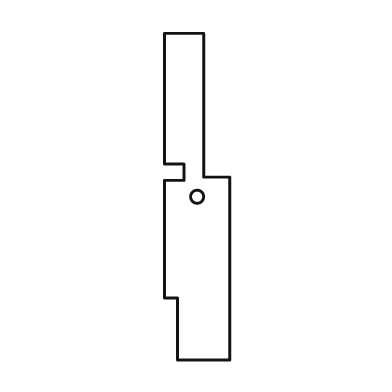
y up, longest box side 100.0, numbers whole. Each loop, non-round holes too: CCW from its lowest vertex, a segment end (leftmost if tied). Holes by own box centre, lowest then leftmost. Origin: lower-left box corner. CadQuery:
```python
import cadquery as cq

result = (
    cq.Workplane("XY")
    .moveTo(4.0, 0.0)
    .lineTo(20.0, 0.0)
    .lineTo(20.0, 56.0)
    .lineTo(12.0, 56.0)
    .lineTo(12.0, 100.0)
    .lineTo(0.0, 100.0)
    .lineTo(0.0, 60.0)
    .lineTo(6.0, 60.0)
    .lineTo(6.0, 55.0)
    .lineTo(0.0, 55.0)
    .lineTo(0.0, 19.0)
    .lineTo(4.0, 19.0)
    .close()
    .moveTo(10.0, 50.0)
    .circle(2.0)
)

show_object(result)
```